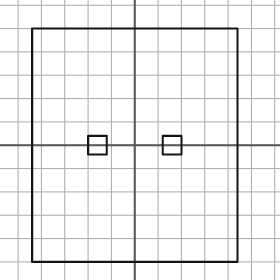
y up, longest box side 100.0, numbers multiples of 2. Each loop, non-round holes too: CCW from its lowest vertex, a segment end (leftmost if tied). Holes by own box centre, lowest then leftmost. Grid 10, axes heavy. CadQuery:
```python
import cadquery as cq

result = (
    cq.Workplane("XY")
    .moveTo(-44.0, -50.0)
    .lineTo(44.0, -50.0)
    .lineTo(44.0, 50.0)
    .lineTo(-44.0, 50.0)
    .close()
    .moveTo(-20.0, -4.0)
    .lineTo(-12.0, -4.0)
    .lineTo(-12.0, 4.0)
    .lineTo(-20.0, 4.0)
    .close()
    .moveTo(12.0, -4.0)
    .lineTo(20.0, -4.0)
    .lineTo(20.0, 4.0)
    .lineTo(12.0, 4.0)
    .close()
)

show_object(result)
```